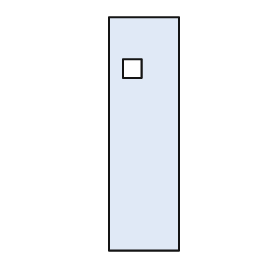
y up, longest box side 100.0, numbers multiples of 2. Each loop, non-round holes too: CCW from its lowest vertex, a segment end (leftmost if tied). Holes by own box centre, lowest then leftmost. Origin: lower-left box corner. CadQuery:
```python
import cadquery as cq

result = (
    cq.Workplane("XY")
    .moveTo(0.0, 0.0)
    .lineTo(30.0, 0.0)
    .lineTo(30.0, 100.0)
    .lineTo(0.0, 100.0)
    .close()
    .moveTo(6.0, 74.0)
    .lineTo(14.0, 74.0)
    .lineTo(14.0, 82.0)
    .lineTo(6.0, 82.0)
    .close()
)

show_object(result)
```